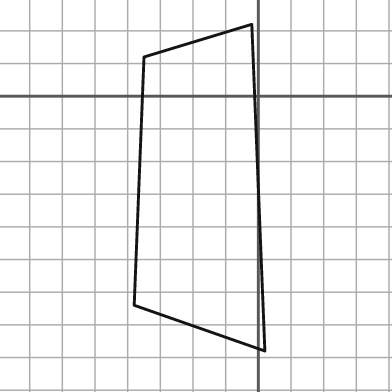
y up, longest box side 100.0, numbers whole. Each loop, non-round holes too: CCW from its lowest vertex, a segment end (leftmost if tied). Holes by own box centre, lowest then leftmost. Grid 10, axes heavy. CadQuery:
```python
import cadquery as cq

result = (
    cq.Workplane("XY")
    .moveTo(2.0, -78.0)
    .lineTo(-2.0, 22.0)
    .lineTo(-35.0, 12.0)
    .lineTo(-38.0, -64.0)
    .close()
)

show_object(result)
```